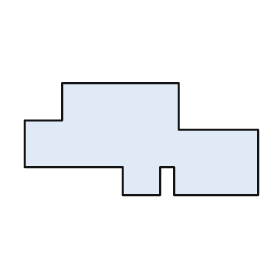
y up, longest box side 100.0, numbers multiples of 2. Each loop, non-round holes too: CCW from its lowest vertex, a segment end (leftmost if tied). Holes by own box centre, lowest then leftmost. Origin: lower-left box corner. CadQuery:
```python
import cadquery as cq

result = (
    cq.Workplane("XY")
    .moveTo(42.0, 0.0)
    .lineTo(58.0, 0.0)
    .lineTo(58.0, 12.0)
    .lineTo(64.0, 12.0)
    .lineTo(64.0, 0.0)
    .lineTo(100.0, 0.0)
    .lineTo(100.0, 28.0)
    .lineTo(66.0, 28.0)
    .lineTo(66.0, 48.0)
    .lineTo(16.0, 48.0)
    .lineTo(16.0, 32.0)
    .lineTo(0.0, 32.0)
    .lineTo(0.0, 12.0)
    .lineTo(42.0, 12.0)
    .close()
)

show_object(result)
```